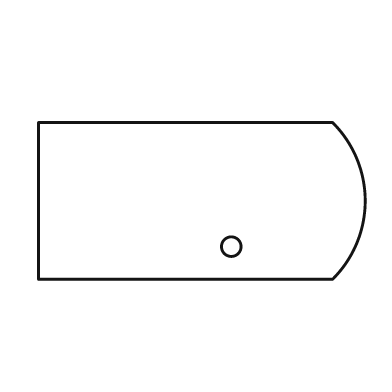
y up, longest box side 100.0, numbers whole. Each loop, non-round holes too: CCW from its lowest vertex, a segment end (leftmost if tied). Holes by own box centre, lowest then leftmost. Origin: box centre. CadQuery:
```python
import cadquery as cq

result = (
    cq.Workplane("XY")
    .moveTo(-50.0, -24.0)
    .lineTo(40.0, -24.0)
    .threePointArc((50.0, 0.0), (40.0, 24.0))
    .lineTo(-50.0, 24.0)
    .close()
    .moveTo(9.0, -14.0)
    .circle(3.0)
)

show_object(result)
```